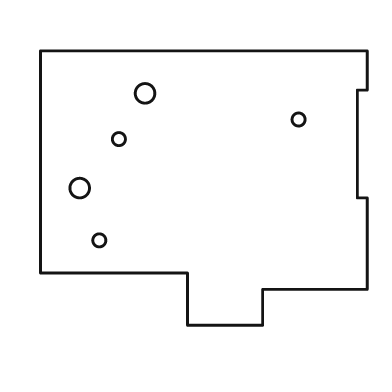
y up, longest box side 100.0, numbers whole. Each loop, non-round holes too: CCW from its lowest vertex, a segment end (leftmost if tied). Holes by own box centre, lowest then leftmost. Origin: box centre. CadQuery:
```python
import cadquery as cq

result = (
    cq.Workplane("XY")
    .moveTo(-5.0, -42.0)
    .lineTo(18.0, -42.0)
    .lineTo(18.0, -31.0)
    .lineTo(50.0, -31.0)
    .lineTo(50.0, -3.0)
    .lineTo(47.0, -3.0)
    .lineTo(47.0, 30.0)
    .lineTo(50.0, 30.0)
    .lineTo(50.0, 42.0)
    .lineTo(-50.0, 42.0)
    .lineTo(-50.0, -26.0)
    .lineTo(-5.0, -26.0)
    .close()
    .moveTo(-32.0, -16.0)
    .circle(2.0)
    .moveTo(-38.0, 0.0)
    .circle(3.0)
    .moveTo(-26.0, 15.0)
    .circle(2.0)
    .moveTo(29.0, 21.0)
    .circle(2.0)
    .moveTo(-18.0, 29.0)
    .circle(3.0)
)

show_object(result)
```